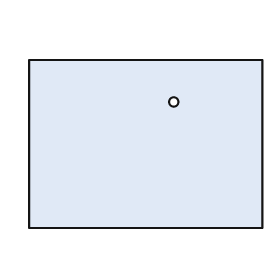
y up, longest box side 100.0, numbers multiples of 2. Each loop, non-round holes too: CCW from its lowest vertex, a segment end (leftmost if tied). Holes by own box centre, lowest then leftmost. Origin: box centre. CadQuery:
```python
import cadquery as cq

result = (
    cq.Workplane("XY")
    .moveTo(-50.0, -36.0)
    .lineTo(50.0, -36.0)
    .lineTo(50.0, 36.0)
    .lineTo(-50.0, 36.0)
    .close()
    .moveTo(12.0, 18.0)
    .circle(2.0)
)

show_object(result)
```